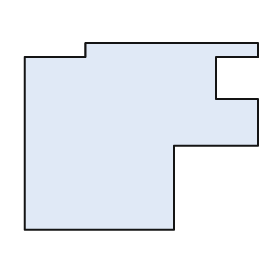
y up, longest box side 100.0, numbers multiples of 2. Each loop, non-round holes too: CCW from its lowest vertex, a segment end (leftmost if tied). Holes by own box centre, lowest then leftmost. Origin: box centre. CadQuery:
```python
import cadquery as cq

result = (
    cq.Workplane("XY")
    .moveTo(-50.0, -40.0)
    .lineTo(14.0, -40.0)
    .lineTo(14.0, -4.0)
    .lineTo(50.0, -4.0)
    .lineTo(50.0, 16.0)
    .lineTo(32.0, 16.0)
    .lineTo(32.0, 34.0)
    .lineTo(50.0, 34.0)
    .lineTo(50.0, 40.0)
    .lineTo(-24.0, 40.0)
    .lineTo(-24.0, 34.0)
    .lineTo(-50.0, 34.0)
    .close()
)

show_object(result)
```